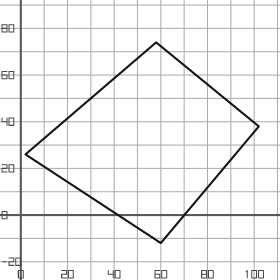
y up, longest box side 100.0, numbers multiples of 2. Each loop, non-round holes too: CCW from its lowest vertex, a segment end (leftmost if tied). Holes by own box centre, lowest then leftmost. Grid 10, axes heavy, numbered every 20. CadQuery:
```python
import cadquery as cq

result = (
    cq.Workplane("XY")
    .moveTo(60.0, -12.0)
    .lineTo(102.0, 38.0)
    .lineTo(58.0, 74.0)
    .lineTo(2.0, 26.0)
    .close()
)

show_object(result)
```